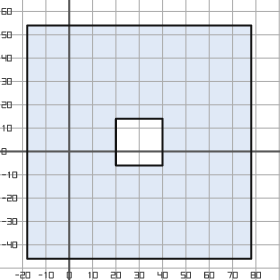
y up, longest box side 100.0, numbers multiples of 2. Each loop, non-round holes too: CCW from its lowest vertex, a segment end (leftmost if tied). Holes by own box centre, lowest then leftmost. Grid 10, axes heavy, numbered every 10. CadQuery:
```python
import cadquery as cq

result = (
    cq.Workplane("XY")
    .moveTo(-18.0, -46.0)
    .lineTo(78.0, -46.0)
    .lineTo(78.0, 54.0)
    .lineTo(-18.0, 54.0)
    .close()
    .moveTo(20.0, -6.0)
    .lineTo(40.0, -6.0)
    .lineTo(40.0, 14.0)
    .lineTo(20.0, 14.0)
    .close()
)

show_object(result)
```